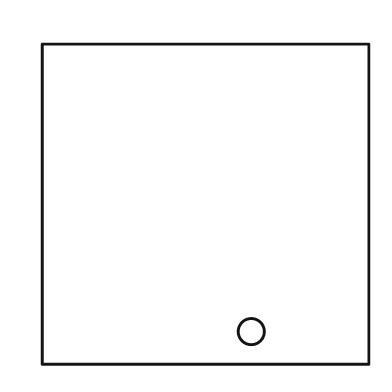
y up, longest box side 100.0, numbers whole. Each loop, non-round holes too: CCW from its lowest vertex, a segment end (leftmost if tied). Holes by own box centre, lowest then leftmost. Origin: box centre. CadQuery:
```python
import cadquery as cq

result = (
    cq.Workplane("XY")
    .moveTo(-50.0, -49.0)
    .lineTo(50.0, -49.0)
    .lineTo(50.0, 49.0)
    .lineTo(-50.0, 49.0)
    .close()
    .moveTo(14.0, -39.0)
    .circle(4.0)
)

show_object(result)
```